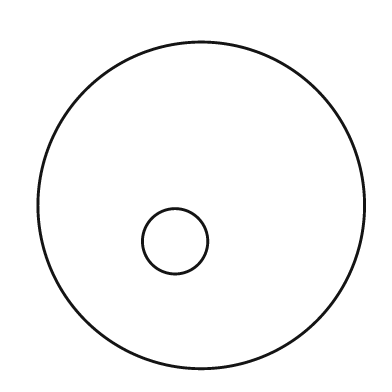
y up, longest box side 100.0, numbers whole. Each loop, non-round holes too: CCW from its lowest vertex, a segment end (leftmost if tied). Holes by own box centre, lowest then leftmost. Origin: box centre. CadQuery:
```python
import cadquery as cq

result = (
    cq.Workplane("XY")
    .moveTo(0.0, 0.0)
    .circle(50.0)
    .moveTo(-8.0, -11.0)
    .circle(10.0)
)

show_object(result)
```